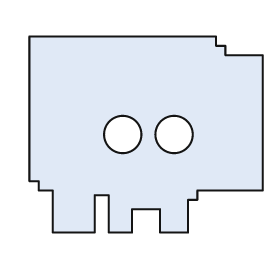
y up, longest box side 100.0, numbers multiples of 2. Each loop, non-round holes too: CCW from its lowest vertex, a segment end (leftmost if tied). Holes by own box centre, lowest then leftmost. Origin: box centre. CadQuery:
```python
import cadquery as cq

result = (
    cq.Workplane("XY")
    .moveTo(-40.0, -42.0)
    .lineTo(-22.0, -42.0)
    .lineTo(-22.0, -26.0)
    .lineTo(-16.0, -26.0)
    .lineTo(-16.0, -42.0)
    .lineTo(-6.0, -42.0)
    .lineTo(-6.0, -32.0)
    .lineTo(6.0, -32.0)
    .lineTo(6.0, -42.0)
    .lineTo(18.0, -42.0)
    .lineTo(18.0, -28.0)
    .lineTo(22.0, -28.0)
    .lineTo(22.0, -24.0)
    .lineTo(50.0, -24.0)
    .lineTo(50.0, 34.0)
    .lineTo(34.0, 34.0)
    .lineTo(34.0, 38.0)
    .lineTo(30.0, 38.0)
    .lineTo(30.0, 42.0)
    .lineTo(-50.0, 42.0)
    .lineTo(-50.0, -20.0)
    .lineTo(-46.0, -20.0)
    .lineTo(-46.0, -24.0)
    .lineTo(-40.0, -24.0)
    .close()
    .moveTo(-10.0, 0.0)
    .circle(8.0)
    .moveTo(12.0, 0.0)
    .circle(8.0)
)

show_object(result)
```